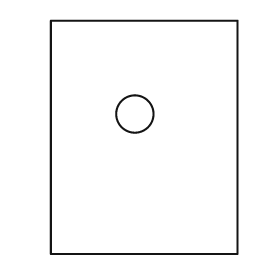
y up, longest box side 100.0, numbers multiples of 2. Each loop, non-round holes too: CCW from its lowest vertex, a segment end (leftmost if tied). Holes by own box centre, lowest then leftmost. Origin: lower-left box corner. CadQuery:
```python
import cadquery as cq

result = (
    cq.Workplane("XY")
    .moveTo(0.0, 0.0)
    .lineTo(80.0, 0.0)
    .lineTo(80.0, 100.0)
    .lineTo(0.0, 100.0)
    .close()
    .moveTo(36.0, 60.0)
    .circle(8.0)
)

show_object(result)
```